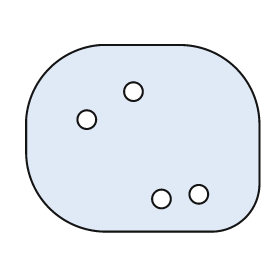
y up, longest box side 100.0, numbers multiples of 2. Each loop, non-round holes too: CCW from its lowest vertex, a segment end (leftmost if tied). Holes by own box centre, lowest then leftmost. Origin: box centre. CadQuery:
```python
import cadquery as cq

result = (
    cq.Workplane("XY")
    .moveTo(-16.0, -40.0)
    .lineTo(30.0, -40.0)
    .threePointArc((44.0, -34.0), (50.0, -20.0))
    .lineTo(50.0, 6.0)
    .threePointArc((40.0, 30.0), (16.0, 40.0))
    .lineTo(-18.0, 40.0)
    .threePointArc((-40.0, 30.0), (-50.0, 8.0))
    .lineTo(-50.0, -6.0)
    .threePointArc((-40.0, -30.0), (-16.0, -40.0))
    .close()
    .moveTo(8.0, -26.0)
    .circle(4.0)
    .moveTo(24.0, -24.0)
    .circle(4.0)
    .moveTo(-24.0, 8.0)
    .circle(4.0)
    .moveTo(-4.0, 20.0)
    .circle(4.0)
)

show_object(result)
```